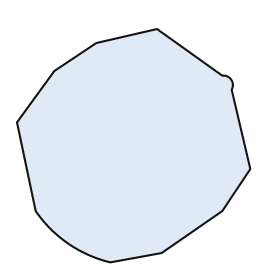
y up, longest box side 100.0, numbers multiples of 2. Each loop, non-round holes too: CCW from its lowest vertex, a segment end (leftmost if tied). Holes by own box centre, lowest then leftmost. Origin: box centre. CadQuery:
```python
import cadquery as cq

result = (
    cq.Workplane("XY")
    .moveTo(-10.0, -50.0)
    .lineTo(12.0, -46.0)
    .lineTo(38.0, -28.0)
    .lineTo(50.0, -10.0)
    .lineTo(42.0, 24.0)
    .threePointArc((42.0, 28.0), (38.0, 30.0))
    .lineTo(10.0, 50.0)
    .lineTo(-16.0, 44.0)
    .lineTo(-34.0, 32.0)
    .lineTo(-50.0, 10.0)
    .lineTo(-42.0, -28.0)
    .threePointArc((-28.0, -42.0), (-10.0, -50.0))
    .close()
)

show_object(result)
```